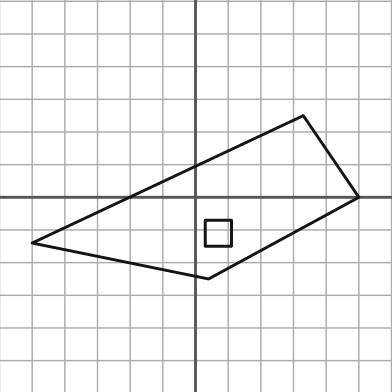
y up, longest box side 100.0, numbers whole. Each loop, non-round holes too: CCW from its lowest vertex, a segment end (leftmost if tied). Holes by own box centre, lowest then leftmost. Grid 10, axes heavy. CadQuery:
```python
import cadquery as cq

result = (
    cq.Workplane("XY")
    .moveTo(4.0, -25.0)
    .lineTo(50.0, 0.0)
    .lineTo(33.0, 25.0)
    .lineTo(-50.0, -14.0)
    .close()
    .moveTo(3.0, -15.0)
    .lineTo(11.0, -15.0)
    .lineTo(11.0, -7.0)
    .lineTo(3.0, -7.0)
    .close()
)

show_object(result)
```